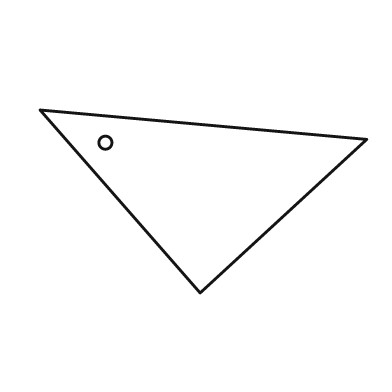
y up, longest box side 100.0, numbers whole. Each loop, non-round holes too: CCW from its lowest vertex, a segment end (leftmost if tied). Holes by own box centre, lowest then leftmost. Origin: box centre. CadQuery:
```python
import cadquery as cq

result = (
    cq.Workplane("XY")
    .moveTo(-1.0, -28.0)
    .lineTo(50.0, 19.0)
    .lineTo(-50.0, 28.0)
    .close()
    .moveTo(-30.0, 18.0)
    .circle(2.0)
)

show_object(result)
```